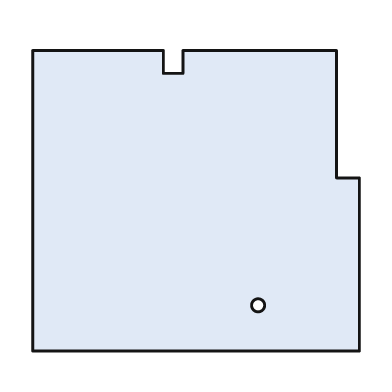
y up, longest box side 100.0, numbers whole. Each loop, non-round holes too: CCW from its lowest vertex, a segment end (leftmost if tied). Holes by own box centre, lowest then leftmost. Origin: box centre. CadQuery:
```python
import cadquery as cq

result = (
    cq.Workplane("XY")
    .moveTo(-50.0, -46.0)
    .lineTo(50.0, -46.0)
    .lineTo(50.0, 7.0)
    .lineTo(43.0, 7.0)
    .lineTo(43.0, 46.0)
    .lineTo(-4.0, 46.0)
    .lineTo(-4.0, 39.0)
    .lineTo(-10.0, 39.0)
    .lineTo(-10.0, 46.0)
    .lineTo(-50.0, 46.0)
    .close()
    .moveTo(19.0, -32.0)
    .circle(2.0)
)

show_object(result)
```